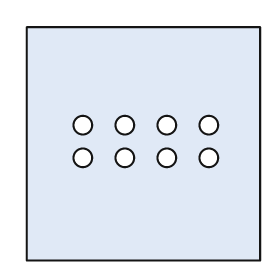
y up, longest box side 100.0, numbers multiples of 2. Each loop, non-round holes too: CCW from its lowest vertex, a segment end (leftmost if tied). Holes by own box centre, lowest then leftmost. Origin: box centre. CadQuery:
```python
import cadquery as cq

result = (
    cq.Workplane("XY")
    .moveTo(-50.0, -50.0)
    .lineTo(50.0, -50.0)
    .lineTo(50.0, 50.0)
    .lineTo(-50.0, 50.0)
    .close()
    .moveTo(-26.0, -6.0)
    .circle(4.0)
    .moveTo(-8.0, -6.0)
    .circle(4.0)
    .moveTo(10.0, -6.0)
    .circle(4.0)
    .moveTo(28.0, -6.0)
    .circle(4.0)
    .moveTo(-26.0, 8.0)
    .circle(4.0)
    .moveTo(-8.0, 8.0)
    .circle(4.0)
    .moveTo(10.0, 8.0)
    .circle(4.0)
    .moveTo(28.0, 8.0)
    .circle(4.0)
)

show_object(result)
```